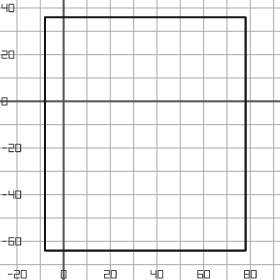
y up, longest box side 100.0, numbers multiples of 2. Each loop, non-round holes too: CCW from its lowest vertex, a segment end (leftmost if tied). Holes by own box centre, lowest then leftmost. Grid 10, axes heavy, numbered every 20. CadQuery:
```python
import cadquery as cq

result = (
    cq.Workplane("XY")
    .moveTo(-8.0, -64.0)
    .lineTo(78.0, -64.0)
    .lineTo(78.0, 36.0)
    .lineTo(-8.0, 36.0)
    .close()
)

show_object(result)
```